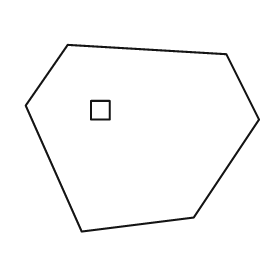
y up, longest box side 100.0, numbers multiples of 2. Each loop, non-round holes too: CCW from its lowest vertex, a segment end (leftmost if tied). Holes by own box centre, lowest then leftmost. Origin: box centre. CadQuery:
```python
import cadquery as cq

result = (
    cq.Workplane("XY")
    .moveTo(-26.0, -40.0)
    .lineTo(22.0, -34.0)
    .lineTo(50.0, 8.0)
    .lineTo(36.0, 36.0)
    .lineTo(-32.0, 40.0)
    .lineTo(-50.0, 14.0)
    .close()
    .moveTo(-22.0, 8.0)
    .lineTo(-14.0, 8.0)
    .lineTo(-14.0, 16.0)
    .lineTo(-22.0, 16.0)
    .close()
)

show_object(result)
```